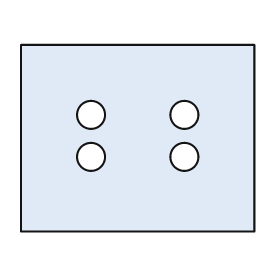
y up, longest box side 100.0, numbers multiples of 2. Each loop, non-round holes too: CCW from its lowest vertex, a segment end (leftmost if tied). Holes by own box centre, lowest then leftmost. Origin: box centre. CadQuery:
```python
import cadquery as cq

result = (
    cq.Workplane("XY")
    .moveTo(-50.0, -40.0)
    .lineTo(50.0, -40.0)
    .lineTo(50.0, 40.0)
    .lineTo(-50.0, 40.0)
    .close()
    .moveTo(-20.0, -8.0)
    .circle(6.0)
    .moveTo(20.0, -8.0)
    .circle(6.0)
    .moveTo(-20.0, 10.0)
    .circle(6.0)
    .moveTo(20.0, 10.0)
    .circle(6.0)
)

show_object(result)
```